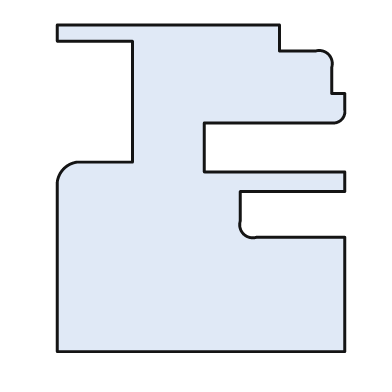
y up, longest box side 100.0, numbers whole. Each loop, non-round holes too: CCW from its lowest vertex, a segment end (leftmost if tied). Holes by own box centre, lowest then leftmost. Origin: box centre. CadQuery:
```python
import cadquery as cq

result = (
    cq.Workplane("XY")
    .moveTo(-44.0, -50.0)
    .lineTo(44.0, -50.0)
    .lineTo(44.0, -15.0)
    .lineTo(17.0, -15.0)
    .threePointArc((13.0, -14.0), (12.0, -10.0))
    .lineTo(12.0, -1.0)
    .lineTo(44.0, -1.0)
    .lineTo(44.0, 5.0)
    .lineTo(1.0, 5.0)
    .lineTo(1.0, 20.0)
    .lineTo(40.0, 20.0)
    .threePointArc((43.0, 21.0), (44.0, 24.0))
    .lineTo(44.0, 29.0)
    .lineTo(40.0, 29.0)
    .lineTo(40.0, 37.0)
    .threePointArc((39.0, 41.0), (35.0, 42.0))
    .lineTo(24.0, 42.0)
    .lineTo(24.0, 50.0)
    .lineTo(-44.0, 50.0)
    .lineTo(-44.0, 45.0)
    .lineTo(-21.0, 45.0)
    .lineTo(-21.0, 8.0)
    .lineTo(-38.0, 8.0)
    .threePointArc((-42.0, 6.0), (-44.0, 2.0))
    .close()
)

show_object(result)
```